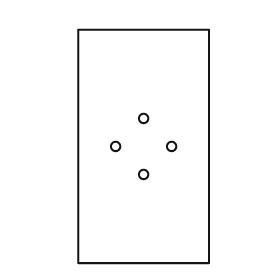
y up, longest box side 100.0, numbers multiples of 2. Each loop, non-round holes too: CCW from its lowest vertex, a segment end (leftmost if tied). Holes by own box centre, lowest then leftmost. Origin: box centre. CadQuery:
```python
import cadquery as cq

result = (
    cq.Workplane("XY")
    .moveTo(-28.0, -50.0)
    .lineTo(28.0, -50.0)
    .lineTo(28.0, 50.0)
    .lineTo(-28.0, 50.0)
    .close()
    .moveTo(0.0, -12.0)
    .circle(2.0)
    .moveTo(-12.0, 0.0)
    .circle(2.0)
    .moveTo(12.0, 0.0)
    .circle(2.0)
    .moveTo(0.0, 12.0)
    .circle(2.0)
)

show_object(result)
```